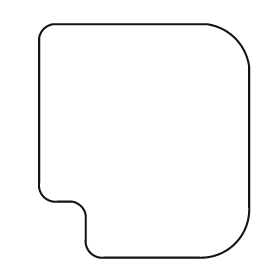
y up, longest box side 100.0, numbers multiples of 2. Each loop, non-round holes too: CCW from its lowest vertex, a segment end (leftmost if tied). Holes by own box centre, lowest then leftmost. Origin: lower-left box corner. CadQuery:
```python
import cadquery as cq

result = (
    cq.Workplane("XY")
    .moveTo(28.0, 0.0)
    .lineTo(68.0, 0.0)
    .threePointArc((84.0, 6.0), (90.0, 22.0))
    .lineTo(90.0, 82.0)
    .threePointArc((84.0, 94.0), (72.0, 100.0))
    .lineTo(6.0, 100.0)
    .threePointArc((2.0, 98.0), (0.0, 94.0))
    .lineTo(0.0, 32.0)
    .threePointArc((2.0, 26.0), (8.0, 24.0))
    .lineTo(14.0, 24.0)
    .threePointArc((18.0, 22.0), (20.0, 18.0))
    .lineTo(20.0, 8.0)
    .threePointArc((22.0, 2.0), (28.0, 0.0))
    .close()
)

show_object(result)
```